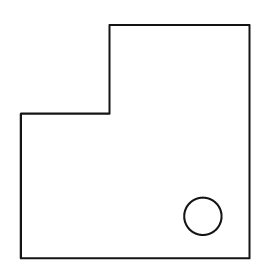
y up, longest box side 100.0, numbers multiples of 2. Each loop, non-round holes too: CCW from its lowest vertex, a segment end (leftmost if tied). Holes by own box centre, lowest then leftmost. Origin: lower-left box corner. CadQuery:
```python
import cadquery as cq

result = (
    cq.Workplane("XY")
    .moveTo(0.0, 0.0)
    .lineTo(98.0, 0.0)
    .lineTo(98.0, 100.0)
    .lineTo(38.0, 100.0)
    .lineTo(38.0, 62.0)
    .lineTo(0.0, 62.0)
    .close()
    .moveTo(78.0, 18.0)
    .circle(8.0)
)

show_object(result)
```